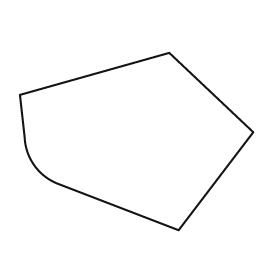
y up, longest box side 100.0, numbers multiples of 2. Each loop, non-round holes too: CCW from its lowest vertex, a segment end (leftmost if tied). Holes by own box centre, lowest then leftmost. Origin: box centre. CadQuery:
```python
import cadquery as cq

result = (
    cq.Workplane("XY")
    .moveTo(18.0, -38.0)
    .lineTo(50.0, 4.0)
    .lineTo(14.0, 38.0)
    .lineTo(-50.0, 20.0)
    .lineTo(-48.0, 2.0)
    .threePointArc((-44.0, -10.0), (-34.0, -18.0))
    .close()
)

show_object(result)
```